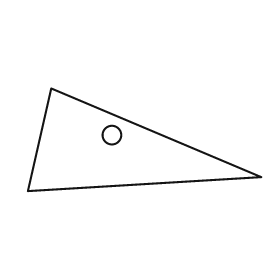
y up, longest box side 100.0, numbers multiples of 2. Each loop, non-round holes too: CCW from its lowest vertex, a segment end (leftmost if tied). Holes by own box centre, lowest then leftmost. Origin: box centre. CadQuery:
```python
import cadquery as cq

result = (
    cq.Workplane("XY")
    .moveTo(-50.0, -22.0)
    .lineTo(50.0, -16.0)
    .lineTo(-40.0, 22.0)
    .close()
    .moveTo(-14.0, 2.0)
    .circle(4.0)
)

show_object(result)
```